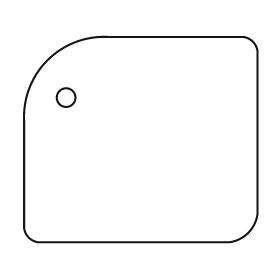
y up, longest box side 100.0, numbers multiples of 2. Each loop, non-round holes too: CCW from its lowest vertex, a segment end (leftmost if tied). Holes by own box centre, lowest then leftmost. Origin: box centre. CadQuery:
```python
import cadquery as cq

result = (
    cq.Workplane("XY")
    .moveTo(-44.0, -44.0)
    .lineTo(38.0, -44.0)
    .threePointArc((46.0, -40.0), (50.0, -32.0))
    .lineTo(50.0, 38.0)
    .threePointArc((48.0, 42.0), (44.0, 44.0))
    .lineTo(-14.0, 44.0)
    .threePointArc((-40.0, 34.0), (-50.0, 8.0))
    .lineTo(-50.0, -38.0)
    .threePointArc((-48.0, -42.0), (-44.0, -44.0))
    .close()
    .moveTo(-32.0, 18.0)
    .circle(4.0)
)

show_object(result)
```